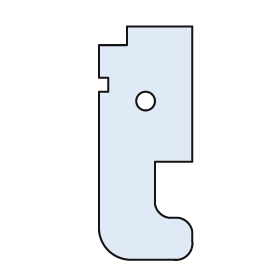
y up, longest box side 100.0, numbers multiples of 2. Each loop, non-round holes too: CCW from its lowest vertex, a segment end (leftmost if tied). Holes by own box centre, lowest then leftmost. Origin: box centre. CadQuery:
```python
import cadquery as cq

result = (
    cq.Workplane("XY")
    .moveTo(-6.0, -50.0)
    .lineTo(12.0, -50.0)
    .threePointArc((18.0, -48.0), (20.0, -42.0))
    .lineTo(20.0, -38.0)
    .threePointArc((18.0, -34.0), (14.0, -32.0))
    .lineTo(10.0, -32.0)
    .threePointArc((6.0, -30.0), (4.0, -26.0))
    .lineTo(4.0, -8.0)
    .lineTo(20.0, -8.0)
    .lineTo(20.0, 50.0)
    .lineTo(-8.0, 50.0)
    .lineTo(-8.0, 42.0)
    .lineTo(-20.0, 42.0)
    .lineTo(-20.0, 28.0)
    .lineTo(-16.0, 28.0)
    .lineTo(-16.0, 22.0)
    .lineTo(-20.0, 22.0)
    .lineTo(-20.0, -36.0)
    .threePointArc((-16.0, -46.0), (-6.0, -50.0))
    .close()
    .moveTo(0.0, 18.0)
    .circle(4.0)
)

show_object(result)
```